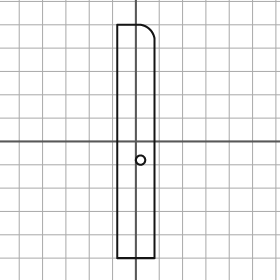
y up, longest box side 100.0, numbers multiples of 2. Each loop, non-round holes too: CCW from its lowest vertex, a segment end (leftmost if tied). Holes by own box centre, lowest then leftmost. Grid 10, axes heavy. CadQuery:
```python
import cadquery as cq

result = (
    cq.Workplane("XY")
    .moveTo(-8.0, -50.0)
    .lineTo(8.0, -50.0)
    .lineTo(8.0, 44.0)
    .threePointArc((6.0, 48.0), (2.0, 50.0))
    .lineTo(-8.0, 50.0)
    .close()
    .moveTo(2.0, -8.0)
    .circle(2.0)
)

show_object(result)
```